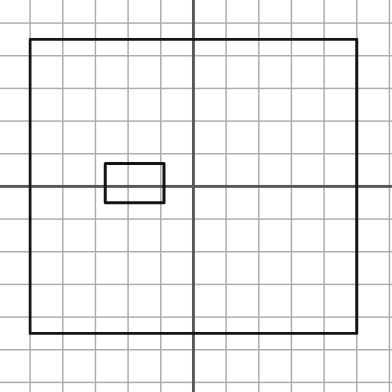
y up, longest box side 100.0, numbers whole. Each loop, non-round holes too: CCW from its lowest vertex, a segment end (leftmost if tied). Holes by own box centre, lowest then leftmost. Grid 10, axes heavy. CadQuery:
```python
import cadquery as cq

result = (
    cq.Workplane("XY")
    .moveTo(-50.0, -45.0)
    .lineTo(50.0, -45.0)
    .lineTo(50.0, 45.0)
    .lineTo(-50.0, 45.0)
    .close()
    .moveTo(-27.0, -5.0)
    .lineTo(-9.0, -5.0)
    .lineTo(-9.0, 7.0)
    .lineTo(-27.0, 7.0)
    .close()
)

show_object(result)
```